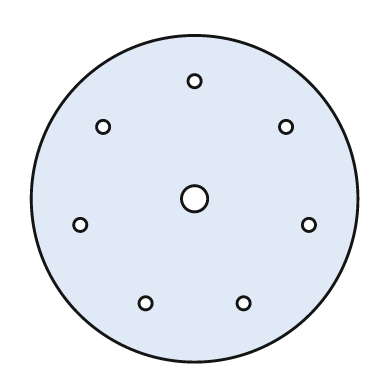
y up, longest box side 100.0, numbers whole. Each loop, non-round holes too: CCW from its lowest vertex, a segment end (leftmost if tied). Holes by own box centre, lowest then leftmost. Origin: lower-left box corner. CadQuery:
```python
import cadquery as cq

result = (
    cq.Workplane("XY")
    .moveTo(50.0, 50.0)
    .circle(50.0)
    .moveTo(35.0, 18.0)
    .circle(2.0)
    .moveTo(65.0, 18.0)
    .circle(2.0)
    .moveTo(15.0, 42.0)
    .circle(2.0)
    .moveTo(85.0, 42.0)
    .circle(2.0)
    .moveTo(50.0, 50.0)
    .circle(4.0)
    .moveTo(22.0, 72.0)
    .circle(2.0)
    .moveTo(78.0, 72.0)
    .circle(2.0)
    .moveTo(50.0, 86.0)
    .circle(2.0)
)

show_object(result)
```